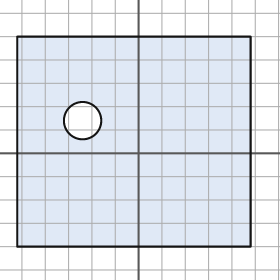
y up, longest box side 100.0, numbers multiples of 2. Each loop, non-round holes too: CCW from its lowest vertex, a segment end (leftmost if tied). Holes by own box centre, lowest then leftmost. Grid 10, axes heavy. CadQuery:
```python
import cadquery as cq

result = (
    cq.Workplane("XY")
    .moveTo(-52.0, -40.0)
    .lineTo(48.0, -40.0)
    .lineTo(48.0, 50.0)
    .lineTo(-52.0, 50.0)
    .close()
    .moveTo(-24.0, 14.0)
    .circle(8.0)
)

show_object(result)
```